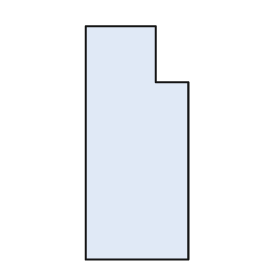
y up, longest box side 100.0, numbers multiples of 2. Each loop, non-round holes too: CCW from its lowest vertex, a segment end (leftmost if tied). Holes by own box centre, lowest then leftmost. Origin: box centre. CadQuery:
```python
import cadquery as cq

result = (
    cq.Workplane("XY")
    .moveTo(-22.0, -50.0)
    .lineTo(22.0, -50.0)
    .lineTo(22.0, 26.0)
    .lineTo(8.0, 26.0)
    .lineTo(8.0, 50.0)
    .lineTo(-22.0, 50.0)
    .close()
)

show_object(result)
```